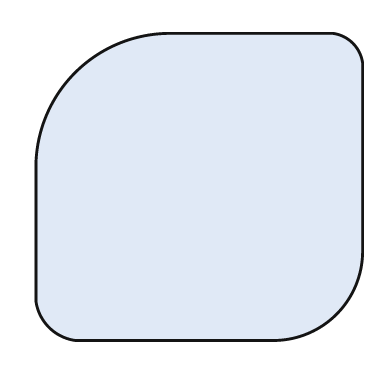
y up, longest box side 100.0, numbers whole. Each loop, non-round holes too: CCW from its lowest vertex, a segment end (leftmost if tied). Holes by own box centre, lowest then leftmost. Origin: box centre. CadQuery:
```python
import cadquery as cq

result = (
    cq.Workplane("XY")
    .moveTo(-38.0, -47.0)
    .lineTo(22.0, -47.0)
    .threePointArc((42.0, -39.0), (50.0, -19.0))
    .lineTo(50.0, 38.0)
    .threePointArc((47.0, 44.0), (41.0, 47.0))
    .lineTo(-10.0, 47.0)
    .threePointArc((-38.0, 35.0), (-50.0, 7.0))
    .lineTo(-50.0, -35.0)
    .threePointArc((-46.0, -43.0), (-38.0, -47.0))
    .close()
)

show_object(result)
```